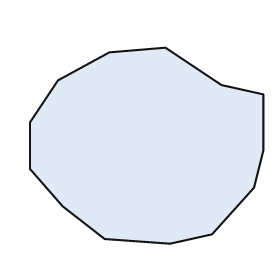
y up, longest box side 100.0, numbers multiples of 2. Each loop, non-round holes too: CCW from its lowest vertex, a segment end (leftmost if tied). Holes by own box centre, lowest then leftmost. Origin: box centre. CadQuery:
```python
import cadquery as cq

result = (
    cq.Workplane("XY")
    .moveTo(10.0, -42.0)
    .lineTo(28.0, -38.0)
    .lineTo(46.0, -18.0)
    .lineTo(50.0, -2.0)
    .lineTo(50.0, 22.0)
    .lineTo(32.0, 26.0)
    .lineTo(8.0, 42.0)
    .lineTo(-16.0, 40.0)
    .lineTo(-38.0, 28.0)
    .lineTo(-50.0, 10.0)
    .lineTo(-50.0, -10.0)
    .lineTo(-36.0, -26.0)
    .lineTo(-18.0, -40.0)
    .close()
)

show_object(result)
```